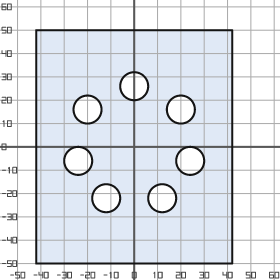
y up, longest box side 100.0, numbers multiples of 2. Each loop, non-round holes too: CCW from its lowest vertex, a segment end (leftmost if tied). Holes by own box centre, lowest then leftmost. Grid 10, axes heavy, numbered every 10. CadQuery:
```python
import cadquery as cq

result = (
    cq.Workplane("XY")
    .moveTo(-42.0, -50.0)
    .lineTo(42.0, -50.0)
    .lineTo(42.0, 50.0)
    .lineTo(-42.0, 50.0)
    .close()
    .moveTo(-12.0, -22.0)
    .circle(6.0)
    .moveTo(12.0, -22.0)
    .circle(6.0)
    .moveTo(-24.0, -6.0)
    .circle(6.0)
    .moveTo(24.0, -6.0)
    .circle(6.0)
    .moveTo(-20.0, 16.0)
    .circle(6.0)
    .moveTo(20.0, 16.0)
    .circle(6.0)
    .moveTo(0.0, 26.0)
    .circle(6.0)
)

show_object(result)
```